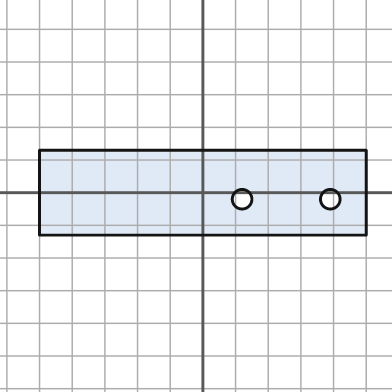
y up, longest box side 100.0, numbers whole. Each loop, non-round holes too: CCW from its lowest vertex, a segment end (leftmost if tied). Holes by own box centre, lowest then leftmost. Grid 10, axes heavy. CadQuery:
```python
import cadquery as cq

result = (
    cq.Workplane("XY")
    .moveTo(-50.0, -13.0)
    .lineTo(50.0, -13.0)
    .lineTo(50.0, 13.0)
    .lineTo(-50.0, 13.0)
    .close()
    .moveTo(12.0, -2.0)
    .circle(3.0)
    .moveTo(39.0, -2.0)
    .circle(3.0)
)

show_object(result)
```